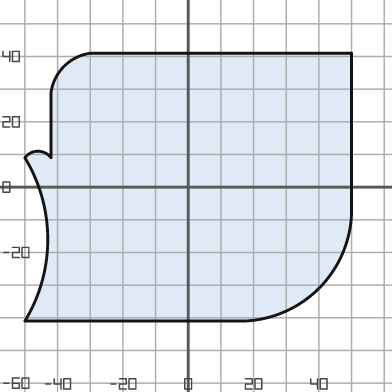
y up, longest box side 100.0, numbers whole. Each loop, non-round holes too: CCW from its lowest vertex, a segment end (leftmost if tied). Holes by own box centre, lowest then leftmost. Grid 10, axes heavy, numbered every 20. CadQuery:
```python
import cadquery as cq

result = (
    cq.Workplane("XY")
    .moveTo(-50.0, -41.0)
    .lineTo(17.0, -41.0)
    .threePointArc((40.0, -31.0), (50.0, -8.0))
    .lineTo(50.0, 41.0)
    .lineTo(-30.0, 41.0)
    .threePointArc((-38.0, 37.0), (-42.0, 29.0))
    .lineTo(-42.0, 9.0)
    .threePointArc((-46.0, 11.0), (-50.0, 9.0))
    .threePointArc((-43.0, -16.0), (-50.0, -41.0))
    .close()
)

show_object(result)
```